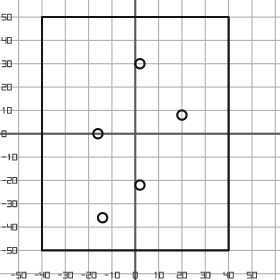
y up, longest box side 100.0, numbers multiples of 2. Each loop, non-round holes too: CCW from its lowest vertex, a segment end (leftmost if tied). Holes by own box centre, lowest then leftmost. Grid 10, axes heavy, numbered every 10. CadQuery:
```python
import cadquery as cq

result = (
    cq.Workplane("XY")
    .moveTo(-40.0, -50.0)
    .lineTo(40.0, -50.0)
    .lineTo(40.0, 50.0)
    .lineTo(-40.0, 50.0)
    .close()
    .moveTo(-14.0, -36.0)
    .circle(2.0)
    .moveTo(2.0, -22.0)
    .circle(2.0)
    .moveTo(-16.0, 0.0)
    .circle(2.0)
    .moveTo(20.0, 8.0)
    .circle(2.0)
    .moveTo(2.0, 30.0)
    .circle(2.0)
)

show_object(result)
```